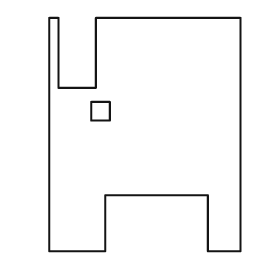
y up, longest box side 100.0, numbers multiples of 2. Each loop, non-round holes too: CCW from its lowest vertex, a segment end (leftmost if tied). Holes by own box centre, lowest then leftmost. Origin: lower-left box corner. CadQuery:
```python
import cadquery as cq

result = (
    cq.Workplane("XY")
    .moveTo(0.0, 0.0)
    .lineTo(24.0, 0.0)
    .lineTo(24.0, 24.0)
    .lineTo(68.0, 24.0)
    .lineTo(68.0, 0.0)
    .lineTo(82.0, 0.0)
    .lineTo(82.0, 100.0)
    .lineTo(20.0, 100.0)
    .lineTo(20.0, 70.0)
    .lineTo(4.0, 70.0)
    .lineTo(4.0, 100.0)
    .lineTo(0.0, 100.0)
    .close()
    .moveTo(18.0, 56.0)
    .lineTo(26.0, 56.0)
    .lineTo(26.0, 64.0)
    .lineTo(18.0, 64.0)
    .close()
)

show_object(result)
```